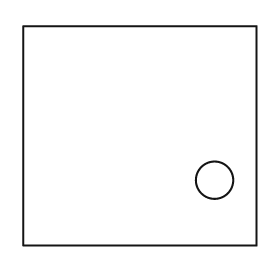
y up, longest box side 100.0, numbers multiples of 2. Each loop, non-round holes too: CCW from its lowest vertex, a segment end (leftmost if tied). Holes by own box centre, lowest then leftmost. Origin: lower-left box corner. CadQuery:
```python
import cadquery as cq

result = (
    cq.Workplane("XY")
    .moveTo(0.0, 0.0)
    .lineTo(100.0, 0.0)
    .lineTo(100.0, 94.0)
    .lineTo(0.0, 94.0)
    .close()
    .moveTo(82.0, 28.0)
    .circle(8.0)
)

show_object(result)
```